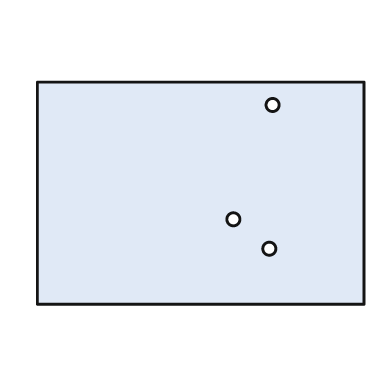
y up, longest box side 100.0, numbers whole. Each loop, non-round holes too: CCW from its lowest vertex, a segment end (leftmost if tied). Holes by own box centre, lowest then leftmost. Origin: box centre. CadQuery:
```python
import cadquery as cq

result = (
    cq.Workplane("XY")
    .moveTo(-50.0, -34.0)
    .lineTo(50.0, -34.0)
    .lineTo(50.0, 34.0)
    .lineTo(-50.0, 34.0)
    .close()
    .moveTo(21.0, -17.0)
    .circle(2.0)
    .moveTo(10.0, -8.0)
    .circle(2.0)
    .moveTo(22.0, 27.0)
    .circle(2.0)
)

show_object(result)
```